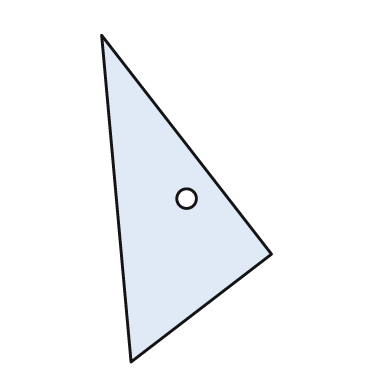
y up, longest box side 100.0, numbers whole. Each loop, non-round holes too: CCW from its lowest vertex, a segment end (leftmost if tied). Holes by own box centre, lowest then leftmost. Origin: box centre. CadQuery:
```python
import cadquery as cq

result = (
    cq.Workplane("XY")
    .moveTo(-17.0, -50.0)
    .lineTo(26.0, -17.0)
    .lineTo(-26.0, 50.0)
    .close()
    .moveTo(0.0, 0.0)
    .circle(3.0)
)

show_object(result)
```